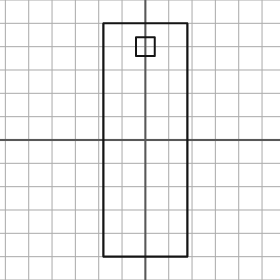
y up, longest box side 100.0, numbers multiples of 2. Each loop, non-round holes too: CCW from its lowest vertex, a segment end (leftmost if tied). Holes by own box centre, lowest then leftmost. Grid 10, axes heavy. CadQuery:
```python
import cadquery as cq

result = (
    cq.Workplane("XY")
    .moveTo(-18.0, -50.0)
    .lineTo(18.0, -50.0)
    .lineTo(18.0, 50.0)
    .lineTo(-18.0, 50.0)
    .close()
    .moveTo(-4.0, 36.0)
    .lineTo(4.0, 36.0)
    .lineTo(4.0, 44.0)
    .lineTo(-4.0, 44.0)
    .close()
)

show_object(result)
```